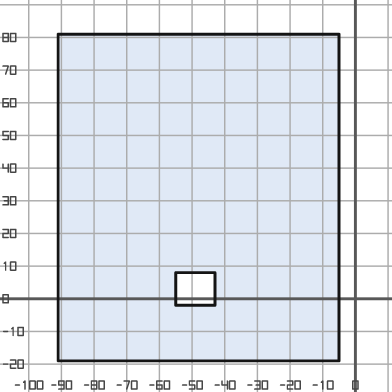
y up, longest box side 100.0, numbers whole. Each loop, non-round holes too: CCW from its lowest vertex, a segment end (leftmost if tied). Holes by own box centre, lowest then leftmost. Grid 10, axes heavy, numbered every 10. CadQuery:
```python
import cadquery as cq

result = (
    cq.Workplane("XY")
    .moveTo(-91.0, -19.0)
    .lineTo(-5.0, -19.0)
    .lineTo(-5.0, 81.0)
    .lineTo(-91.0, 81.0)
    .close()
    .moveTo(-55.0, -2.0)
    .lineTo(-43.0, -2.0)
    .lineTo(-43.0, 8.0)
    .lineTo(-55.0, 8.0)
    .close()
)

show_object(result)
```